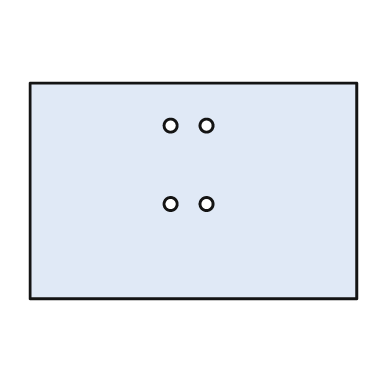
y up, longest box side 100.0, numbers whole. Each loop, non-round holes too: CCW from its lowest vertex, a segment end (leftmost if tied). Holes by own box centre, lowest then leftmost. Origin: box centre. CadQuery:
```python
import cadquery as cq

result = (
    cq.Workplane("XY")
    .moveTo(-50.0, -33.0)
    .lineTo(50.0, -33.0)
    .lineTo(50.0, 33.0)
    .lineTo(-50.0, 33.0)
    .close()
    .moveTo(-7.0, -4.0)
    .circle(2.0)
    .moveTo(4.0, -4.0)
    .circle(2.0)
    .moveTo(-7.0, 20.0)
    .circle(2.0)
    .moveTo(4.0, 20.0)
    .circle(2.0)
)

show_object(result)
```